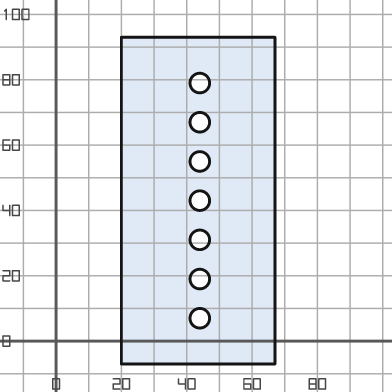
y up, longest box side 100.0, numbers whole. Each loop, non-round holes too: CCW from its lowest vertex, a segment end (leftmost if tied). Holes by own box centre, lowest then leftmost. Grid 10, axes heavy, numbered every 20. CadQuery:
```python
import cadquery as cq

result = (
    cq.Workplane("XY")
    .moveTo(20.0, -7.0)
    .lineTo(67.0, -7.0)
    .lineTo(67.0, 93.0)
    .lineTo(20.0, 93.0)
    .close()
    .moveTo(44.0, 7.0)
    .circle(3.0)
    .moveTo(44.0, 19.0)
    .circle(3.0)
    .moveTo(44.0, 31.0)
    .circle(3.0)
    .moveTo(44.0, 43.0)
    .circle(3.0)
    .moveTo(44.0, 55.0)
    .circle(3.0)
    .moveTo(44.0, 67.0)
    .circle(3.0)
    .moveTo(44.0, 79.0)
    .circle(3.0)
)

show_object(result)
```